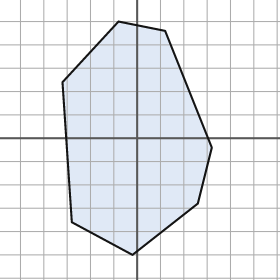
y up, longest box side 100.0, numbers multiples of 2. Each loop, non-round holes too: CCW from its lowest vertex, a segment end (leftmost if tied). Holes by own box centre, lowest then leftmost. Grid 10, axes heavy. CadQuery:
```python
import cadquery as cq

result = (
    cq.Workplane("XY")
    .moveTo(-2.0, -50.0)
    .lineTo(26.0, -28.0)
    .lineTo(32.0, -4.0)
    .lineTo(12.0, 46.0)
    .lineTo(-8.0, 50.0)
    .lineTo(-32.0, 24.0)
    .lineTo(-28.0, -36.0)
    .close()
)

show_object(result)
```